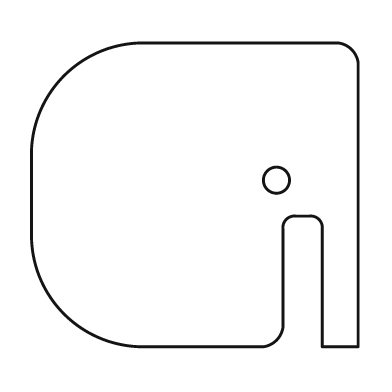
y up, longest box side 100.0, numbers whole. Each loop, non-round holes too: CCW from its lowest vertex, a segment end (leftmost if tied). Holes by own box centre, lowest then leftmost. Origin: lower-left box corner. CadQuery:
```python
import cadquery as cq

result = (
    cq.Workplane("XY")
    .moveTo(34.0, 0.0)
    .lineTo(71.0, 0.0)
    .threePointArc((75.0, 2.0), (77.0, 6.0))
    .lineTo(77.0, 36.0)
    .threePointArc((78.0, 39.0), (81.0, 40.0))
    .lineTo(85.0, 40.0)
    .threePointArc((88.0, 39.0), (89.0, 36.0))
    .lineTo(89.0, 0.0)
    .lineTo(100.0, 0.0)
    .lineTo(100.0, 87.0)
    .threePointArc((98.0, 91.0), (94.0, 93.0))
    .lineTo(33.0, 93.0)
    .threePointArc((10.0, 83.0), (0.0, 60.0))
    .lineTo(0.0, 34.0)
    .threePointArc((10.0, 10.0), (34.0, 0.0))
    .close()
    .moveTo(75.0, 51.0)
    .circle(4.0)
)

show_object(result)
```